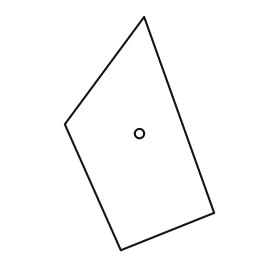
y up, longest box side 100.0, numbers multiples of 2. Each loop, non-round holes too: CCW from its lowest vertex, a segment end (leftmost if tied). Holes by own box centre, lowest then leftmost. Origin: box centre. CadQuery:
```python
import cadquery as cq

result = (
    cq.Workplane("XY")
    .moveTo(-8.0, -50.0)
    .lineTo(32.0, -34.0)
    .lineTo(2.0, 50.0)
    .lineTo(-32.0, 4.0)
    .close()
    .moveTo(0.0, 0.0)
    .circle(2.0)
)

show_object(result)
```